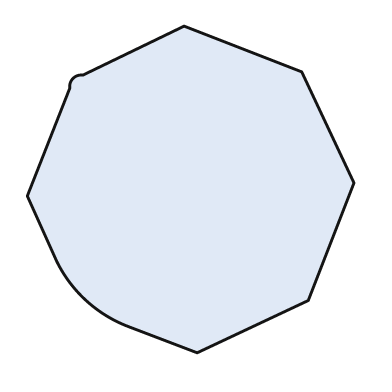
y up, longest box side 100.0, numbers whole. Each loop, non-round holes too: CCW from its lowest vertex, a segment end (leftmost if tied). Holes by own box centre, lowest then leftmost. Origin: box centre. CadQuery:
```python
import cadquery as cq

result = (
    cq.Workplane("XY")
    .moveTo(2.0, -50.0)
    .lineTo(36.0, -34.0)
    .lineTo(50.0, 2.0)
    .lineTo(34.0, 36.0)
    .lineTo(-2.0, 50.0)
    .lineTo(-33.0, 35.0)
    .threePointArc((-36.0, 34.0), (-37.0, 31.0))
    .lineTo(-50.0, -2.0)
    .lineTo(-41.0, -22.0)
    .threePointArc((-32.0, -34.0), (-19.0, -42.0))
    .close()
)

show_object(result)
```